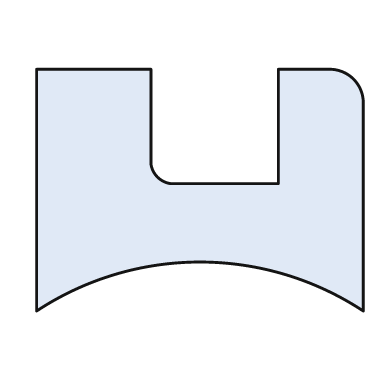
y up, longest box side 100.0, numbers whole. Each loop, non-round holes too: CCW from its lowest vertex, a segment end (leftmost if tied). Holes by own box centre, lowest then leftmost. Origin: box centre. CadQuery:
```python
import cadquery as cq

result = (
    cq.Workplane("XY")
    .moveTo(-50.0, -37.0)
    .threePointArc((0.0, -22.0), (50.0, -37.0))
    .lineTo(50.0, 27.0)
    .threePointArc((47.0, 34.0), (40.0, 37.0))
    .lineTo(24.0, 37.0)
    .lineTo(24.0, 2.0)
    .lineTo(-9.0, 2.0)
    .threePointArc((-13.0, 4.0), (-15.0, 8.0))
    .lineTo(-15.0, 37.0)
    .lineTo(-50.0, 37.0)
    .close()
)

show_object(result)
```